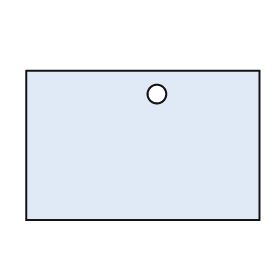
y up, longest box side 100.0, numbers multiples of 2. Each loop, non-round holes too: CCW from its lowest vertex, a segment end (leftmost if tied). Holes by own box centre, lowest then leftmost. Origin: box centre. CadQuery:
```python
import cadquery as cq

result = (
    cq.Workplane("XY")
    .moveTo(-50.0, -32.0)
    .lineTo(50.0, -32.0)
    .lineTo(50.0, 32.0)
    .lineTo(-50.0, 32.0)
    .close()
    .moveTo(6.0, 22.0)
    .circle(4.0)
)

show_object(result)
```